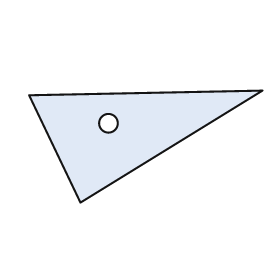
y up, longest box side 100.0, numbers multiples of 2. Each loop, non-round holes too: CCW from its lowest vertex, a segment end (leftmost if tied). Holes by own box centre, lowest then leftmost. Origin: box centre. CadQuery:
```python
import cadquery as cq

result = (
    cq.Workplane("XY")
    .moveTo(-28.0, -24.0)
    .lineTo(50.0, 24.0)
    .lineTo(-50.0, 22.0)
    .close()
    .moveTo(-16.0, 10.0)
    .circle(4.0)
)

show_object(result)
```